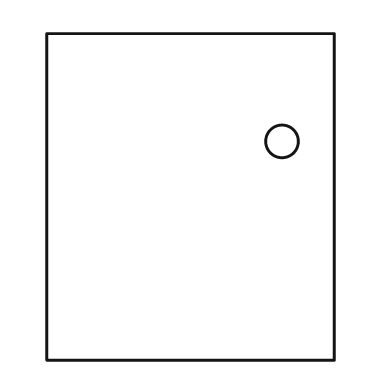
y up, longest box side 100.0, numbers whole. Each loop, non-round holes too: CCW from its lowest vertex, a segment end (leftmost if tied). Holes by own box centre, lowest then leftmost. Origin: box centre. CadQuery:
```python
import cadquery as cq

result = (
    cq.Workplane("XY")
    .moveTo(-44.0, -50.0)
    .lineTo(44.0, -50.0)
    .lineTo(44.0, 50.0)
    .lineTo(-44.0, 50.0)
    .close()
    .moveTo(28.0, 17.0)
    .circle(5.0)
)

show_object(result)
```